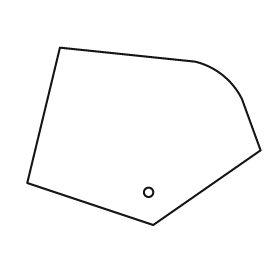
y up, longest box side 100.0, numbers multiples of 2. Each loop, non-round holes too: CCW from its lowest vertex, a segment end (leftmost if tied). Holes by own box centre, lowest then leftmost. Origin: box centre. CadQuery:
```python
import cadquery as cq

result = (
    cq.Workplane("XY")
    .moveTo(4.0, -38.0)
    .lineTo(50.0, -6.0)
    .lineTo(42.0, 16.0)
    .threePointArc((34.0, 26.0), (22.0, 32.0))
    .lineTo(-36.0, 38.0)
    .lineTo(-50.0, -20.0)
    .close()
    .moveTo(2.0, -24.0)
    .circle(2.0)
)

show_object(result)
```